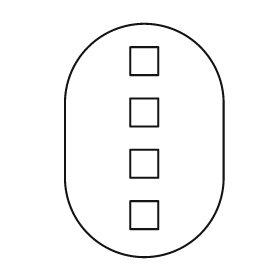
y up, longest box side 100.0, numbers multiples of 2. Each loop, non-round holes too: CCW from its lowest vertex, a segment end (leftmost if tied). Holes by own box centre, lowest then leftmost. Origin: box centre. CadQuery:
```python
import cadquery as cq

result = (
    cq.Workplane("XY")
    .moveTo(-34.0, -16.0)
    .threePointArc((0.0, -50.0), (34.0, -16.0))
    .lineTo(34.0, 16.0)
    .threePointArc((0.0, 50.0), (-34.0, 16.0))
    .close()
    .moveTo(-6.0, -38.0)
    .lineTo(6.0, -38.0)
    .lineTo(6.0, -26.0)
    .lineTo(-6.0, -26.0)
    .close()
    .moveTo(-6.0, -16.0)
    .lineTo(6.0, -16.0)
    .lineTo(6.0, -4.0)
    .lineTo(-6.0, -4.0)
    .close()
    .moveTo(-6.0, 6.0)
    .lineTo(6.0, 6.0)
    .lineTo(6.0, 18.0)
    .lineTo(-6.0, 18.0)
    .close()
    .moveTo(-6.0, 28.0)
    .lineTo(6.0, 28.0)
    .lineTo(6.0, 40.0)
    .lineTo(-6.0, 40.0)
    .close()
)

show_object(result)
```